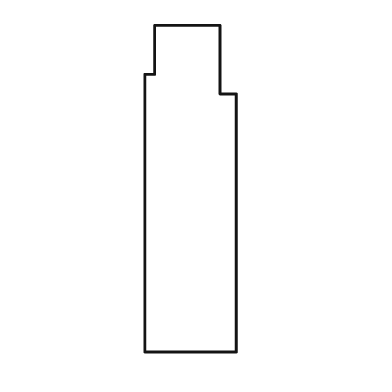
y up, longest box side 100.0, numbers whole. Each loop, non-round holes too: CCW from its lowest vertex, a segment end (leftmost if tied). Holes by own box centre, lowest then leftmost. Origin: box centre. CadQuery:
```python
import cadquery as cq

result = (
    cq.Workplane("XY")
    .moveTo(-14.0, -50.0)
    .lineTo(14.0, -50.0)
    .lineTo(14.0, 29.0)
    .lineTo(9.0, 29.0)
    .lineTo(9.0, 50.0)
    .lineTo(-11.0, 50.0)
    .lineTo(-11.0, 35.0)
    .lineTo(-14.0, 35.0)
    .close()
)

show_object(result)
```